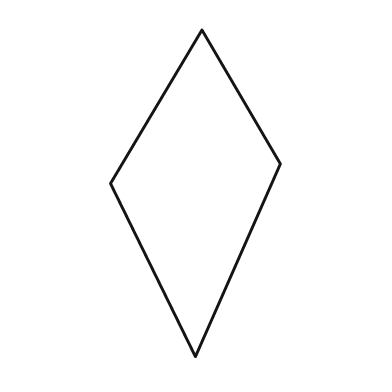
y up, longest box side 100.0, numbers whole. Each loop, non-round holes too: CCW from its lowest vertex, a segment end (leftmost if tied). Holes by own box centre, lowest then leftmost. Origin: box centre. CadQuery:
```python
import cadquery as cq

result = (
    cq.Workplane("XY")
    .moveTo(0.0, -50.0)
    .lineTo(26.0, 9.0)
    .lineTo(2.0, 50.0)
    .lineTo(-26.0, 3.0)
    .close()
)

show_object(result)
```